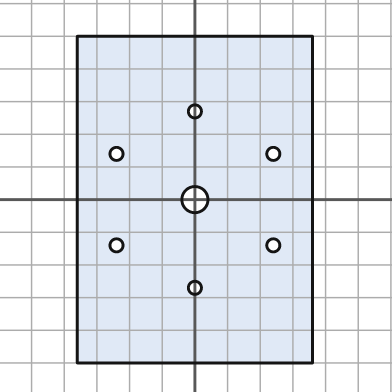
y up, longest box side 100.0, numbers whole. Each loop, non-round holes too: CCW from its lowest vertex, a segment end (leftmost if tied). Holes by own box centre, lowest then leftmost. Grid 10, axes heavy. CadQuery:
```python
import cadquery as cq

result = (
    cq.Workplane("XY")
    .moveTo(-36.0, -50.0)
    .lineTo(36.0, -50.0)
    .lineTo(36.0, 50.0)
    .lineTo(-36.0, 50.0)
    .close()
    .moveTo(0.0, -27.0)
    .circle(2.0)
    .moveTo(-24.0, -14.0)
    .circle(2.0)
    .moveTo(24.0, -14.0)
    .circle(2.0)
    .moveTo(0.0, 0.0)
    .circle(4.0)
    .moveTo(-24.0, 14.0)
    .circle(2.0)
    .moveTo(24.0, 14.0)
    .circle(2.0)
    .moveTo(0.0, 27.0)
    .circle(2.0)
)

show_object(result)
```